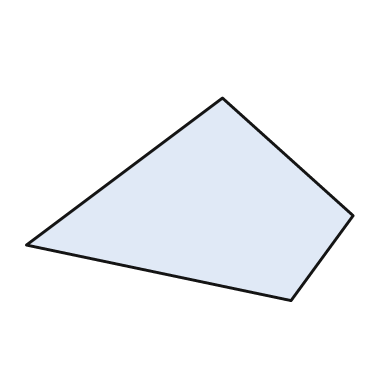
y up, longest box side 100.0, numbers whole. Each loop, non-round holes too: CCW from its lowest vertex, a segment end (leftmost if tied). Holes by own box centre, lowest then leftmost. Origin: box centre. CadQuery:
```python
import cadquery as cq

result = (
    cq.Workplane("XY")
    .moveTo(31.0, -31.0)
    .lineTo(50.0, -5.0)
    .lineTo(10.0, 31.0)
    .lineTo(-50.0, -14.0)
    .close()
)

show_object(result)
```